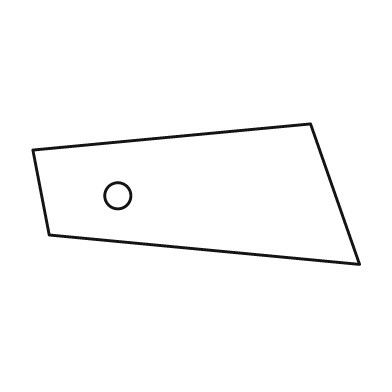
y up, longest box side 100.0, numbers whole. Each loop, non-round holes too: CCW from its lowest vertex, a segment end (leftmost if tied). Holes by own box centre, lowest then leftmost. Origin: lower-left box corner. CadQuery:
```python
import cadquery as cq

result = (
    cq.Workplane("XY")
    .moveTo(100.0, 0.0)
    .lineTo(85.0, 43.0)
    .lineTo(0.0, 35.0)
    .lineTo(5.0, 9.0)
    .close()
    .moveTo(26.0, 21.0)
    .circle(4.0)
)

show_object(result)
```